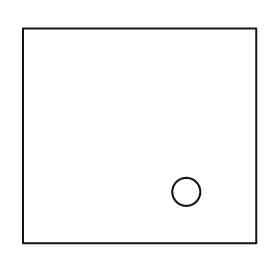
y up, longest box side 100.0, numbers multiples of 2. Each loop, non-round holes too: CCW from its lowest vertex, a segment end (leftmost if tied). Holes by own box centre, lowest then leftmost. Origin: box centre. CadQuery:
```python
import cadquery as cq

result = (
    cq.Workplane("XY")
    .moveTo(-50.0, -46.0)
    .lineTo(50.0, -46.0)
    .lineTo(50.0, 46.0)
    .lineTo(-50.0, 46.0)
    .close()
    .moveTo(20.0, -24.0)
    .circle(6.0)
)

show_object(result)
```